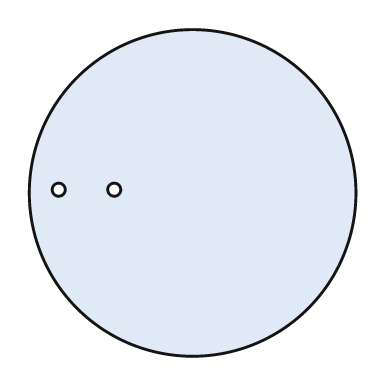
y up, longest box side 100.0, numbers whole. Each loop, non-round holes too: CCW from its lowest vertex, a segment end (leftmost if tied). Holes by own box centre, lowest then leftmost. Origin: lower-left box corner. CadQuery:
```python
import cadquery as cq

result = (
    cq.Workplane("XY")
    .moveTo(50.0, 50.0)
    .circle(50.0)
    .moveTo(9.0, 51.0)
    .circle(2.0)
    .moveTo(26.0, 51.0)
    .circle(2.0)
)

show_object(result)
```